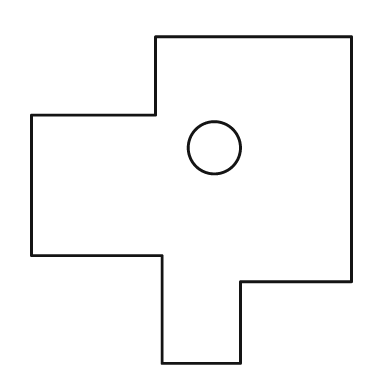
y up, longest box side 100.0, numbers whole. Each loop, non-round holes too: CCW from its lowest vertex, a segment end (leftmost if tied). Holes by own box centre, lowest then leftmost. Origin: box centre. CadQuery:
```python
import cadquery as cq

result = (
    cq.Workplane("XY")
    .moveTo(-9.0, -50.0)
    .lineTo(15.0, -50.0)
    .lineTo(15.0, -25.0)
    .lineTo(49.0, -25.0)
    .lineTo(49.0, 50.0)
    .lineTo(-11.0, 50.0)
    .lineTo(-11.0, 26.0)
    .lineTo(-49.0, 26.0)
    .lineTo(-49.0, -17.0)
    .lineTo(-9.0, -17.0)
    .close()
    .moveTo(7.0, 16.0)
    .circle(8.0)
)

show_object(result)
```